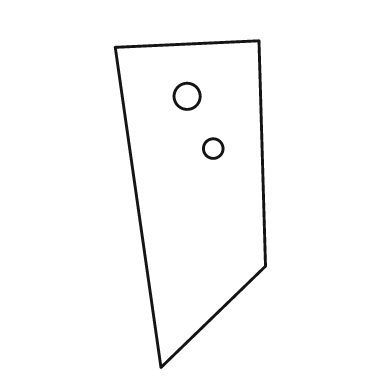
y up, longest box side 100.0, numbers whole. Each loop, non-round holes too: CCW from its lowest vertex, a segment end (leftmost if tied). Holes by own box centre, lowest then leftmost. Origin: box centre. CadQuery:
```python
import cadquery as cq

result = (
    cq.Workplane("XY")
    .moveTo(-9.0, -50.0)
    .lineTo(23.0, -19.0)
    .lineTo(21.0, 50.0)
    .lineTo(-23.0, 48.0)
    .close()
    .moveTo(7.0, 17.0)
    .circle(3.0)
    .moveTo(-1.0, 33.0)
    .circle(4.0)
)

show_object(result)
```